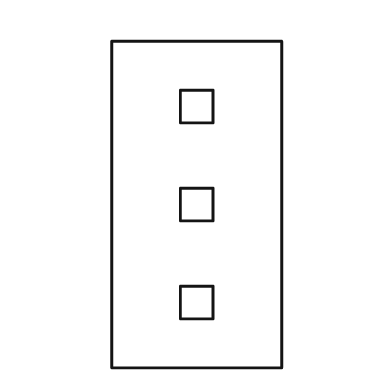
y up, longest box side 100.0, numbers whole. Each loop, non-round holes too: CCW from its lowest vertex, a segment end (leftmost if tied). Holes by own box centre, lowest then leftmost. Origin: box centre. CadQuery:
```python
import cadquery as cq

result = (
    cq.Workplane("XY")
    .moveTo(-26.0, -50.0)
    .lineTo(26.0, -50.0)
    .lineTo(26.0, 50.0)
    .lineTo(-26.0, 50.0)
    .close()
    .moveTo(-5.0, -35.0)
    .lineTo(5.0, -35.0)
    .lineTo(5.0, -25.0)
    .lineTo(-5.0, -25.0)
    .close()
    .moveTo(-5.0, -5.0)
    .lineTo(5.0, -5.0)
    .lineTo(5.0, 5.0)
    .lineTo(-5.0, 5.0)
    .close()
    .moveTo(-5.0, 25.0)
    .lineTo(5.0, 25.0)
    .lineTo(5.0, 35.0)
    .lineTo(-5.0, 35.0)
    .close()
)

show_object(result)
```